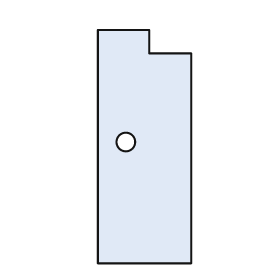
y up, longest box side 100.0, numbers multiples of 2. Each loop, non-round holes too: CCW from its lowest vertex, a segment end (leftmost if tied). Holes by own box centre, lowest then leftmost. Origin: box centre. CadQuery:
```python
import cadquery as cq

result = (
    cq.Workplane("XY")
    .moveTo(-20.0, -50.0)
    .lineTo(20.0, -50.0)
    .lineTo(20.0, 40.0)
    .lineTo(2.0, 40.0)
    .lineTo(2.0, 50.0)
    .lineTo(-20.0, 50.0)
    .close()
    .moveTo(-8.0, 2.0)
    .circle(4.0)
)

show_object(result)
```